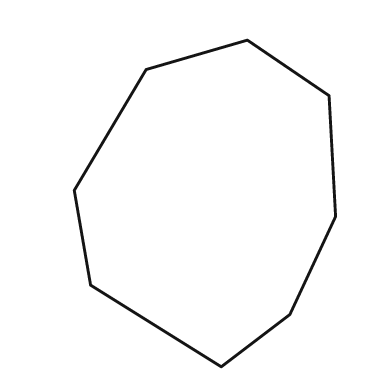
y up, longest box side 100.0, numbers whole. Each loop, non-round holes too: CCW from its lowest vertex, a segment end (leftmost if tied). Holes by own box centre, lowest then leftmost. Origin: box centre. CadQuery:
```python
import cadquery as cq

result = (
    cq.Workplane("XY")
    .moveTo(5.0, -50.0)
    .lineTo(26.0, -34.0)
    .lineTo(40.0, -4.0)
    .lineTo(38.0, 33.0)
    .lineTo(13.0, 50.0)
    .lineTo(-18.0, 41.0)
    .lineTo(-40.0, 4.0)
    .lineTo(-35.0, -25.0)
    .close()
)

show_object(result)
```